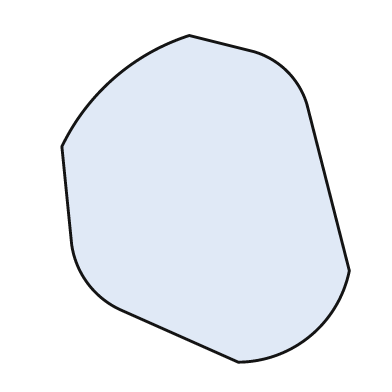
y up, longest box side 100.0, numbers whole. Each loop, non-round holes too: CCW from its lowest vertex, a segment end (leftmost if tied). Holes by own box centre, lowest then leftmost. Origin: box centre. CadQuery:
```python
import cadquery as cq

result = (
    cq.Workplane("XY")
    .moveTo(10.0, -50.0)
    .threePointArc((32.0, -42.0), (44.0, -22.0))
    .lineTo(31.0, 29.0)
    .threePointArc((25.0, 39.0), (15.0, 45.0))
    .lineTo(-5.0, 50.0)
    .threePointArc((-28.0, 37.0), (-44.0, 16.0))
    .lineTo(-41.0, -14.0)
    .threePointArc((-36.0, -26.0), (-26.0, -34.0))
    .close()
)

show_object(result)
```